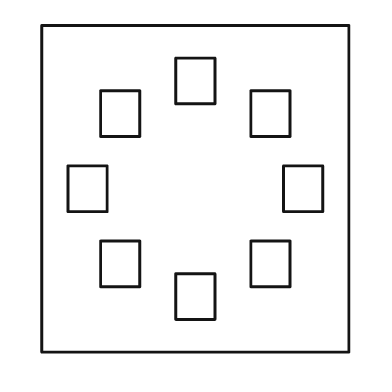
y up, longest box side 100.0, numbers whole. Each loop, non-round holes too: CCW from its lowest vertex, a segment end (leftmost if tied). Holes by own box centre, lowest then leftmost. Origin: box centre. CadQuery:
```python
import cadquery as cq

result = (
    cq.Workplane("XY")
    .moveTo(-47.0, -50.0)
    .lineTo(47.0, -50.0)
    .lineTo(47.0, 50.0)
    .lineTo(-47.0, 50.0)
    .close()
    .moveTo(-6.0, -40.0)
    .lineTo(6.0, -40.0)
    .lineTo(6.0, -26.0)
    .lineTo(-6.0, -26.0)
    .close()
    .moveTo(-29.0, -30.0)
    .lineTo(-17.0, -30.0)
    .lineTo(-17.0, -16.0)
    .lineTo(-29.0, -16.0)
    .close()
    .moveTo(17.0, -30.0)
    .lineTo(29.0, -30.0)
    .lineTo(29.0, -16.0)
    .lineTo(17.0, -16.0)
    .close()
    .moveTo(-39.0, -7.0)
    .lineTo(-27.0, -7.0)
    .lineTo(-27.0, 7.0)
    .lineTo(-39.0, 7.0)
    .close()
    .moveTo(27.0, -7.0)
    .lineTo(39.0, -7.0)
    .lineTo(39.0, 7.0)
    .lineTo(27.0, 7.0)
    .close()
    .moveTo(-29.0, 16.0)
    .lineTo(-17.0, 16.0)
    .lineTo(-17.0, 30.0)
    .lineTo(-29.0, 30.0)
    .close()
    .moveTo(17.0, 16.0)
    .lineTo(29.0, 16.0)
    .lineTo(29.0, 30.0)
    .lineTo(17.0, 30.0)
    .close()
    .moveTo(-6.0, 26.0)
    .lineTo(6.0, 26.0)
    .lineTo(6.0, 40.0)
    .lineTo(-6.0, 40.0)
    .close()
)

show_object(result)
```